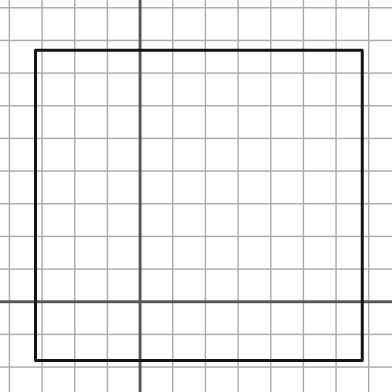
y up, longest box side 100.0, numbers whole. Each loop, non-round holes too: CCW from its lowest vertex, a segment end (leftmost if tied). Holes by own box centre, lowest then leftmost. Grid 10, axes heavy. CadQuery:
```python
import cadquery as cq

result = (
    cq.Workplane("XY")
    .moveTo(-32.0, -18.0)
    .lineTo(68.0, -18.0)
    .lineTo(68.0, 77.0)
    .lineTo(-32.0, 77.0)
    .close()
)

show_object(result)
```